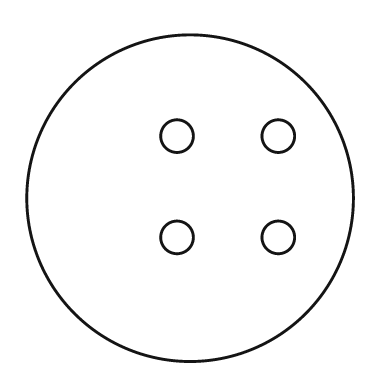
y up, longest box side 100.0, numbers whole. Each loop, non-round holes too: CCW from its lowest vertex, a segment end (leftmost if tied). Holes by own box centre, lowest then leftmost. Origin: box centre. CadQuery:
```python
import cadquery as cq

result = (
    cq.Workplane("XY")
    .moveTo(0.0, 0.0)
    .circle(50.0)
    .moveTo(-4.0, -12.0)
    .circle(5.0)
    .moveTo(27.0, -12.0)
    .circle(5.0)
    .moveTo(-4.0, 19.0)
    .circle(5.0)
    .moveTo(27.0, 19.0)
    .circle(5.0)
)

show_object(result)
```